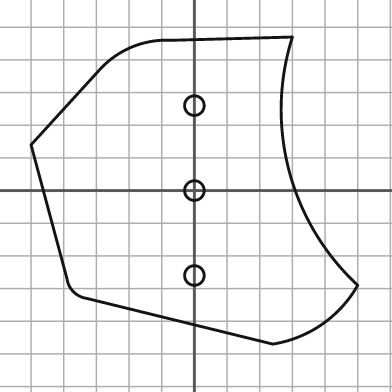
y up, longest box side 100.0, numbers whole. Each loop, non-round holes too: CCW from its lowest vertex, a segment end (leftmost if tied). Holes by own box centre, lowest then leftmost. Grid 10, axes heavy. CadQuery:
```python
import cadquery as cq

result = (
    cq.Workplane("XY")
    .moveTo(24.0, -47.0)
    .threePointArc((39.0, -41.0), (50.0, -29.0))
    .threePointArc((29.0, 6.0), (30.0, 47.0))
    .lineTo(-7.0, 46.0)
    .threePointArc((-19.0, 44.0), (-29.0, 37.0))
    .lineTo(-50.0, 14.0)
    .lineTo(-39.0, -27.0)
    .threePointArc((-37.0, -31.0), (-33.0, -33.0))
    .close()
    .moveTo(0.0, -26.0)
    .circle(3.0)
    .moveTo(0.0, 0.0)
    .circle(3.0)
    .moveTo(0.0, 26.0)
    .circle(3.0)
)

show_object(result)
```